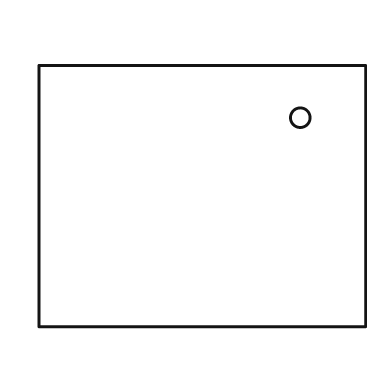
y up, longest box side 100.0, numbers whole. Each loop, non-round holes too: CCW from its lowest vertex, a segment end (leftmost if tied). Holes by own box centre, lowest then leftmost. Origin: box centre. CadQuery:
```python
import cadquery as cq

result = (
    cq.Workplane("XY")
    .moveTo(-50.0, -40.0)
    .lineTo(50.0, -40.0)
    .lineTo(50.0, 40.0)
    .lineTo(-50.0, 40.0)
    .close()
    .moveTo(30.0, 24.0)
    .circle(3.0)
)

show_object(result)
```